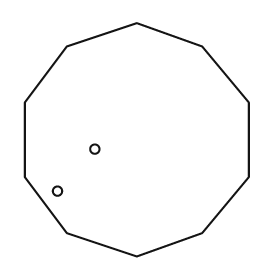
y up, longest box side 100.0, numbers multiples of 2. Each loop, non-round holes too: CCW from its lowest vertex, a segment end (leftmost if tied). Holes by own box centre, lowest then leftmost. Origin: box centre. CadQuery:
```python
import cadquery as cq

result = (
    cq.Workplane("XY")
    .moveTo(0.0, -50.0)
    .lineTo(28.0, -40.0)
    .lineTo(48.0, -16.0)
    .lineTo(48.0, 16.0)
    .lineTo(28.0, 40.0)
    .lineTo(0.0, 50.0)
    .lineTo(-30.0, 40.0)
    .lineTo(-48.0, 16.0)
    .lineTo(-48.0, -16.0)
    .lineTo(-30.0, -40.0)
    .close()
    .moveTo(-34.0, -22.0)
    .circle(2.0)
    .moveTo(-18.0, -4.0)
    .circle(2.0)
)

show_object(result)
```